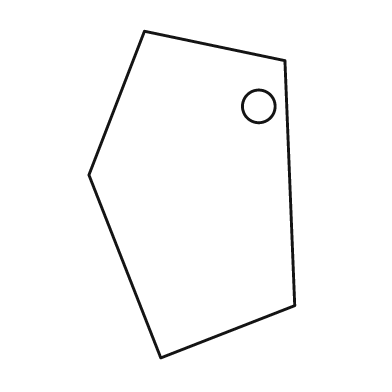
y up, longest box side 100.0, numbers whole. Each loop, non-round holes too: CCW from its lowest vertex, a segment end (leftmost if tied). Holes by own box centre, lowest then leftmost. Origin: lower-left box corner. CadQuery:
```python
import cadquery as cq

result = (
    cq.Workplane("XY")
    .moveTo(22.0, 0.0)
    .lineTo(63.0, 16.0)
    .lineTo(60.0, 91.0)
    .lineTo(17.0, 100.0)
    .lineTo(0.0, 56.0)
    .close()
    .moveTo(52.0, 77.0)
    .circle(5.0)
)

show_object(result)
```